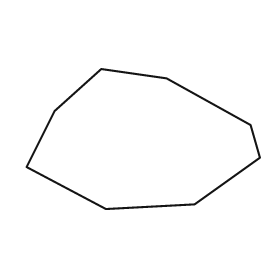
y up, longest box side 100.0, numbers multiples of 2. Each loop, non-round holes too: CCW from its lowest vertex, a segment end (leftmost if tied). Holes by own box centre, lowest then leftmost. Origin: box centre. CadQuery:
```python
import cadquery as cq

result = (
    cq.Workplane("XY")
    .moveTo(-16.0, -30.0)
    .lineTo(22.0, -28.0)
    .lineTo(50.0, -8.0)
    .lineTo(46.0, 6.0)
    .lineTo(10.0, 26.0)
    .lineTo(-18.0, 30.0)
    .lineTo(-38.0, 12.0)
    .lineTo(-50.0, -12.0)
    .close()
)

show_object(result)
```